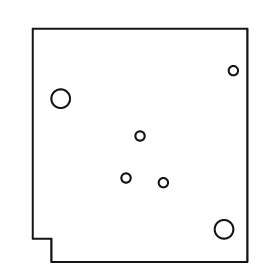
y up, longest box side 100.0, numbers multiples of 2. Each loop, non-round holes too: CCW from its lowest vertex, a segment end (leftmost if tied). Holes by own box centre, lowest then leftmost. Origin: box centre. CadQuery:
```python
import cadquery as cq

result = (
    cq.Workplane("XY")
    .moveTo(-38.0, -50.0)
    .lineTo(46.0, -50.0)
    .lineTo(46.0, 50.0)
    .lineTo(-46.0, 50.0)
    .lineTo(-46.0, -40.0)
    .lineTo(-38.0, -40.0)
    .close()
    .moveTo(36.0, -36.0)
    .circle(4.0)
    .moveTo(10.0, -16.0)
    .circle(2.0)
    .moveTo(-6.0, -14.0)
    .circle(2.0)
    .moveTo(0.0, 4.0)
    .circle(2.0)
    .moveTo(-34.0, 20.0)
    .circle(4.0)
    .moveTo(40.0, 32.0)
    .circle(2.0)
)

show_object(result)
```